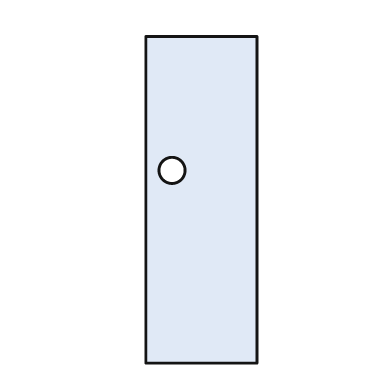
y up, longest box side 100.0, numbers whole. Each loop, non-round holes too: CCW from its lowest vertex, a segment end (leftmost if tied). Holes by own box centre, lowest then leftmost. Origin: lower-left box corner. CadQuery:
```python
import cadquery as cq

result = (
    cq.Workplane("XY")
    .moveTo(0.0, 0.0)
    .lineTo(34.0, 0.0)
    .lineTo(34.0, 100.0)
    .lineTo(0.0, 100.0)
    .close()
    .moveTo(8.0, 59.0)
    .circle(4.0)
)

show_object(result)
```